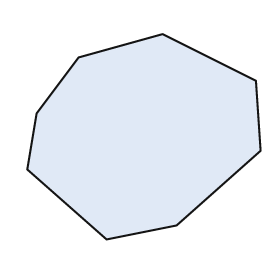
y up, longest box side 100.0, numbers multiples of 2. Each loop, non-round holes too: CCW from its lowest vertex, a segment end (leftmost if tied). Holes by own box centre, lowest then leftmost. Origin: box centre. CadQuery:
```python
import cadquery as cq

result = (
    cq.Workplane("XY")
    .moveTo(-16.0, -44.0)
    .lineTo(14.0, -38.0)
    .lineTo(50.0, -6.0)
    .lineTo(48.0, 24.0)
    .lineTo(8.0, 44.0)
    .lineTo(-28.0, 34.0)
    .lineTo(-46.0, 10.0)
    .lineTo(-50.0, -14.0)
    .close()
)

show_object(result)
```